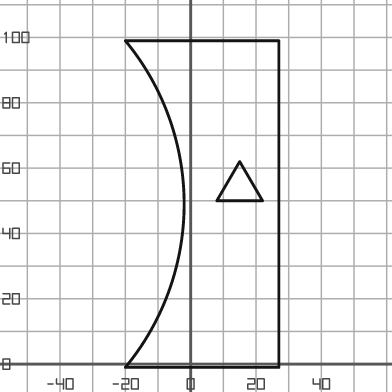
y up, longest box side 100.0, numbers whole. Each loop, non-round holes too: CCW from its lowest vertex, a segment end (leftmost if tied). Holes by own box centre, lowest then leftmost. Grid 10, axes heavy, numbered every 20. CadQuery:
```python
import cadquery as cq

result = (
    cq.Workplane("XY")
    .moveTo(-20.0, -1.0)
    .lineTo(27.0, -1.0)
    .lineTo(27.0, 99.0)
    .lineTo(-20.0, 99.0)
    .threePointArc((-2.0, 49.0), (-20.0, -1.0))
    .close()
    .moveTo(8.0, 50.0)
    .lineTo(22.0, 50.0)
    .lineTo(15.0, 62.0)
    .close()
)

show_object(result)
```